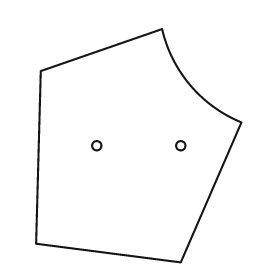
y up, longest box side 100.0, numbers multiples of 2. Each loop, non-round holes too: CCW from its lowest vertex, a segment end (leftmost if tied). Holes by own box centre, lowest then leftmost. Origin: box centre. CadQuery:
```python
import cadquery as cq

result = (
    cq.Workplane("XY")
    .moveTo(18.0, -50.0)
    .lineTo(44.0, 10.0)
    .threePointArc((22.0, 26.0), (10.0, 50.0))
    .lineTo(-42.0, 32.0)
    .lineTo(-44.0, -42.0)
    .close()
    .moveTo(-18.0, 0.0)
    .circle(2.0)
    .moveTo(18.0, 0.0)
    .circle(2.0)
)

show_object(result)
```